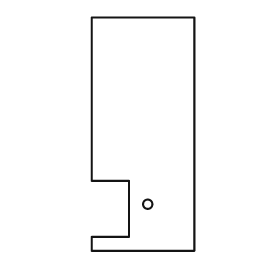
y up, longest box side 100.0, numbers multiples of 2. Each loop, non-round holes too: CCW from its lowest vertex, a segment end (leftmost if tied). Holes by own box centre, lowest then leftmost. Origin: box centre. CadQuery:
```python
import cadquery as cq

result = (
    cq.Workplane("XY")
    .moveTo(-22.0, -50.0)
    .lineTo(22.0, -50.0)
    .lineTo(22.0, 50.0)
    .lineTo(-22.0, 50.0)
    .lineTo(-22.0, -20.0)
    .lineTo(-6.0, -20.0)
    .lineTo(-6.0, -44.0)
    .lineTo(-22.0, -44.0)
    .close()
    .moveTo(2.0, -30.0)
    .circle(2.0)
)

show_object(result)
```